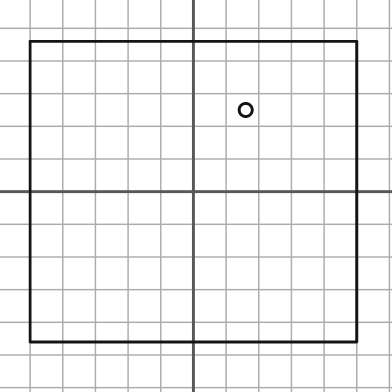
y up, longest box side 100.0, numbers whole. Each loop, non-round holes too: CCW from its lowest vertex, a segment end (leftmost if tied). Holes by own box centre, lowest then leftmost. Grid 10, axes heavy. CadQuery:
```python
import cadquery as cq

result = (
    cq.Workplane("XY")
    .moveTo(-50.0, -46.0)
    .lineTo(50.0, -46.0)
    .lineTo(50.0, 46.0)
    .lineTo(-50.0, 46.0)
    .close()
    .moveTo(16.0, 25.0)
    .circle(2.0)
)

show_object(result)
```